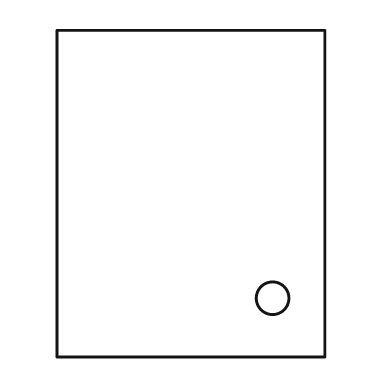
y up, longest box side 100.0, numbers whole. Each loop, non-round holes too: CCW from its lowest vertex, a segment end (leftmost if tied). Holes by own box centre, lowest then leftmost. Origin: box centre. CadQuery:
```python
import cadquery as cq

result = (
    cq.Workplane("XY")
    .moveTo(-41.0, -50.0)
    .lineTo(41.0, -50.0)
    .lineTo(41.0, 50.0)
    .lineTo(-41.0, 50.0)
    .close()
    .moveTo(25.0, -32.0)
    .circle(5.0)
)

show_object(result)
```